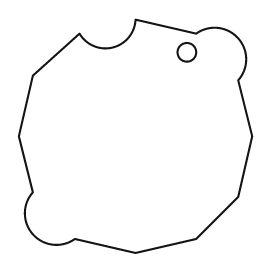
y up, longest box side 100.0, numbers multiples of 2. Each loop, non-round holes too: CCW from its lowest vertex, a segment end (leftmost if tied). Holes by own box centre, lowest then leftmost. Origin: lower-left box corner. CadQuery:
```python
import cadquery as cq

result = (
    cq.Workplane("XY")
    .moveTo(50.0, 0.0)
    .lineTo(76.0, 6.0)
    .lineTo(94.0, 24.0)
    .lineTo(100.0, 50.0)
    .lineTo(94.0, 74.0)
    .threePointArc((94.0, 92.0), (76.0, 94.0))
    .lineTo(50.0, 100.0)
    .threePointArc((40.0, 88.0), (26.0, 94.0))
    .lineTo(6.0, 76.0)
    .lineTo(0.0, 50.0)
    .lineTo(6.0, 26.0)
    .threePointArc((6.0, 8.0), (24.0, 6.0))
    .close()
    .moveTo(72.0, 86.0)
    .circle(4.0)
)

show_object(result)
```